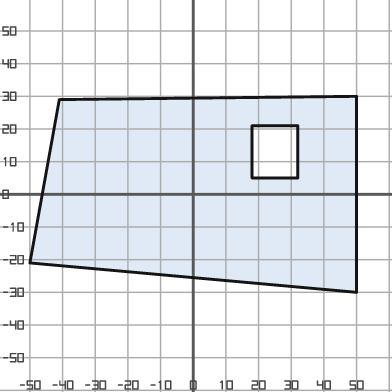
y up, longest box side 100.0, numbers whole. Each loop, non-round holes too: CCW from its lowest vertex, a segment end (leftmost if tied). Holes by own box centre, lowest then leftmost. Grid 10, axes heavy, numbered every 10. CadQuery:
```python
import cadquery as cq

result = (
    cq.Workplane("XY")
    .moveTo(50.0, -30.0)
    .lineTo(50.0, 30.0)
    .lineTo(-41.0, 29.0)
    .lineTo(-50.0, -21.0)
    .close()
    .moveTo(18.0, 5.0)
    .lineTo(32.0, 5.0)
    .lineTo(32.0, 21.0)
    .lineTo(18.0, 21.0)
    .close()
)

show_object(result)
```